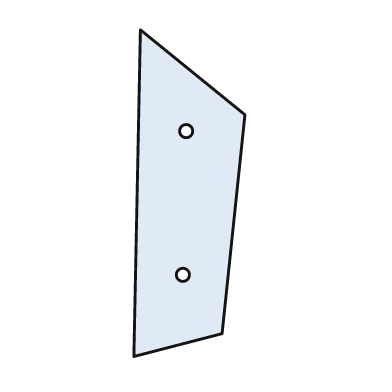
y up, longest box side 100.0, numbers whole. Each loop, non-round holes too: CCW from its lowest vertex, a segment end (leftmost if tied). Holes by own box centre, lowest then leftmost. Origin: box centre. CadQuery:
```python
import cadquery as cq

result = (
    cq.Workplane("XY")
    .moveTo(-17.0, -50.0)
    .lineTo(10.0, -43.0)
    .lineTo(17.0, 24.0)
    .lineTo(-15.0, 50.0)
    .close()
    .moveTo(-2.0, -25.0)
    .circle(2.0)
    .moveTo(-1.0, 19.0)
    .circle(2.0)
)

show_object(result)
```